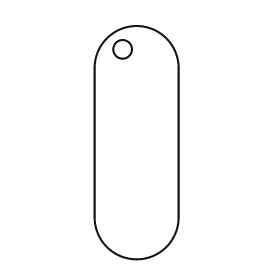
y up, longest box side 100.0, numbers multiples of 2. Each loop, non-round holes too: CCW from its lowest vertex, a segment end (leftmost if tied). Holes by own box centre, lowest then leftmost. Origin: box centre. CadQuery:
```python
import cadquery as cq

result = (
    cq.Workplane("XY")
    .moveTo(-18.0, -32.0)
    .threePointArc((0.0, -50.0), (18.0, -32.0))
    .lineTo(18.0, 32.0)
    .threePointArc((0.0, 50.0), (-18.0, 32.0))
    .close()
    .moveTo(-6.0, 40.0)
    .circle(4.0)
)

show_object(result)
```